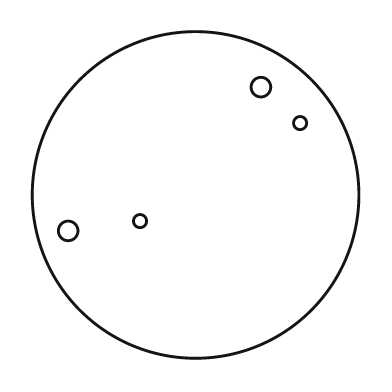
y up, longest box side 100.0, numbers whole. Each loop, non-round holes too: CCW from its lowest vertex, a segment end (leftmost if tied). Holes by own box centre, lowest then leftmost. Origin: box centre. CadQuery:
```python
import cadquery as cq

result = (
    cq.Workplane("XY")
    .moveTo(0.0, 0.0)
    .circle(50.0)
    .moveTo(-39.0, -11.0)
    .circle(3.0)
    .moveTo(-17.0, -8.0)
    .circle(2.0)
    .moveTo(32.0, 22.0)
    .circle(2.0)
    .moveTo(20.0, 33.0)
    .circle(3.0)
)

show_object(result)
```